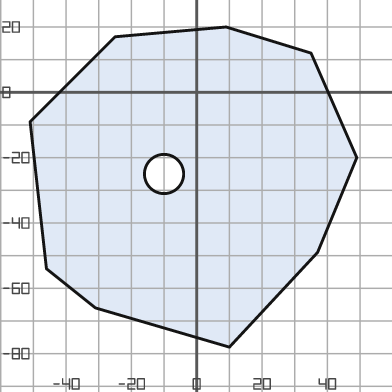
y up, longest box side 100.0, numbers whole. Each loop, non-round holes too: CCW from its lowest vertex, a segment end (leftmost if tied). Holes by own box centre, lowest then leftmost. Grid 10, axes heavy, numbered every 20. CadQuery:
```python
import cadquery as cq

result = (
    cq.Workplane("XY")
    .moveTo(10.0, -78.0)
    .lineTo(37.0, -49.0)
    .lineTo(49.0, -20.0)
    .lineTo(35.0, 12.0)
    .lineTo(9.0, 20.0)
    .lineTo(-25.0, 17.0)
    .lineTo(-51.0, -9.0)
    .lineTo(-46.0, -54.0)
    .lineTo(-31.0, -66.0)
    .close()
    .moveTo(-10.0, -25.0)
    .circle(6.0)
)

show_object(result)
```